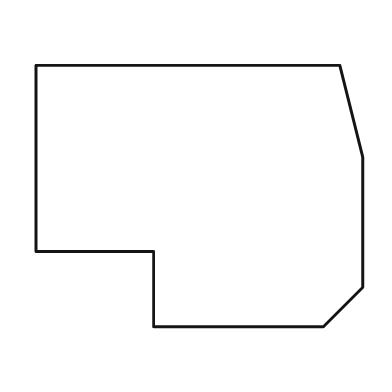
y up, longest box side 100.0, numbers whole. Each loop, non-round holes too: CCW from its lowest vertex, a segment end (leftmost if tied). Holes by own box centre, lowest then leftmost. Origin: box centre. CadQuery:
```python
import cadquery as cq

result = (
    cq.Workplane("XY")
    .moveTo(-14.0, -40.0)
    .lineTo(38.0, -40.0)
    .lineTo(50.0, -28.0)
    .lineTo(50.0, 12.0)
    .lineTo(43.0, 40.0)
    .lineTo(-50.0, 40.0)
    .lineTo(-50.0, -17.0)
    .lineTo(-14.0, -17.0)
    .close()
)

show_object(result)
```